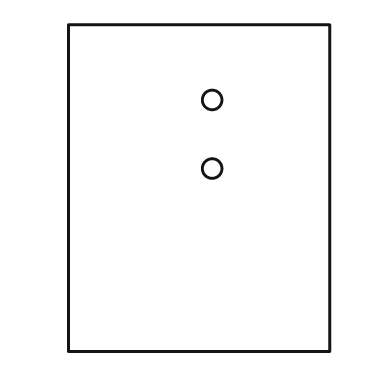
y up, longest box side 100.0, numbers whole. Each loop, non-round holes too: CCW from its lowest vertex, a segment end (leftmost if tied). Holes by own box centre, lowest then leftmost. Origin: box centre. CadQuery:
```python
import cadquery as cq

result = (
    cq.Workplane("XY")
    .moveTo(-40.0, -50.0)
    .lineTo(40.0, -50.0)
    .lineTo(40.0, 50.0)
    .lineTo(-40.0, 50.0)
    .close()
    .moveTo(4.0, 6.0)
    .circle(3.0)
    .moveTo(4.0, 27.0)
    .circle(3.0)
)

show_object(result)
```